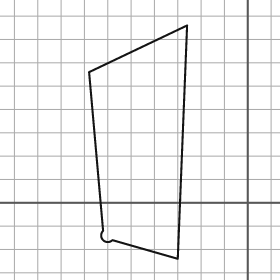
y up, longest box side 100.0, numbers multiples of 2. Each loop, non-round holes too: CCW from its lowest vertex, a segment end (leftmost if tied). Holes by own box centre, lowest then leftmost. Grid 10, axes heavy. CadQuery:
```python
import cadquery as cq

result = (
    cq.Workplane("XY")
    .moveTo(-30.0, -24.0)
    .lineTo(-26.0, 76.0)
    .lineTo(-68.0, 56.0)
    .lineTo(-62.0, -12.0)
    .threePointArc((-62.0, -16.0), (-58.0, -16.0))
    .close()
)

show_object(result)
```